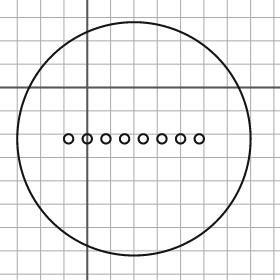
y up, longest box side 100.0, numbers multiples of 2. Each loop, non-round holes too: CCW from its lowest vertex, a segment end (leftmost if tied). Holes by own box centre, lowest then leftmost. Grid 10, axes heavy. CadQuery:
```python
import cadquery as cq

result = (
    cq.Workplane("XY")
    .moveTo(20.0, -22.0)
    .circle(50.0)
    .moveTo(-8.0, -22.0)
    .circle(2.0)
    .moveTo(0.0, -22.0)
    .circle(2.0)
    .moveTo(8.0, -22.0)
    .circle(2.0)
    .moveTo(16.0, -22.0)
    .circle(2.0)
    .moveTo(24.0, -22.0)
    .circle(2.0)
    .moveTo(32.0, -22.0)
    .circle(2.0)
    .moveTo(40.0, -22.0)
    .circle(2.0)
    .moveTo(48.0, -22.0)
    .circle(2.0)
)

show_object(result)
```